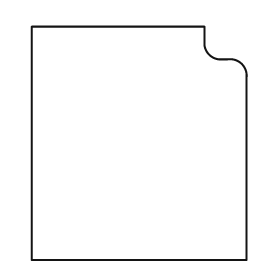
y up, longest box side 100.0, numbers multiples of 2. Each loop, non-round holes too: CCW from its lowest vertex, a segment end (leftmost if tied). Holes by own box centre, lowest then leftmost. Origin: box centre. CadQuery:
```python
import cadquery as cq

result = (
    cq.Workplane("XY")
    .moveTo(-46.0, -50.0)
    .lineTo(46.0, -50.0)
    .lineTo(46.0, 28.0)
    .threePointArc((44.0, 34.0), (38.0, 36.0))
    .lineTo(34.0, 36.0)
    .threePointArc((30.0, 38.0), (28.0, 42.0))
    .lineTo(28.0, 50.0)
    .lineTo(-46.0, 50.0)
    .close()
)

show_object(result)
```